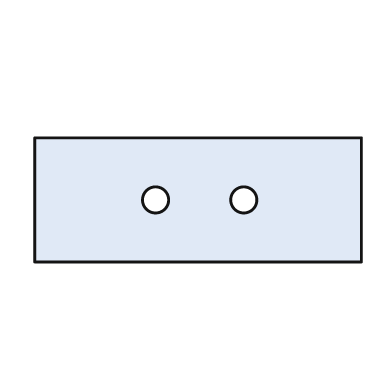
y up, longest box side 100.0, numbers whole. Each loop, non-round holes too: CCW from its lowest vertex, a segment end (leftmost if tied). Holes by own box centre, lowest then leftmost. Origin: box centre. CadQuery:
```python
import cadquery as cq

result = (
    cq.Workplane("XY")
    .moveTo(-50.0, -19.0)
    .lineTo(50.0, -19.0)
    .lineTo(50.0, 19.0)
    .lineTo(-50.0, 19.0)
    .close()
    .moveTo(-13.0, 0.0)
    .circle(4.0)
    .moveTo(14.0, 0.0)
    .circle(4.0)
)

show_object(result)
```